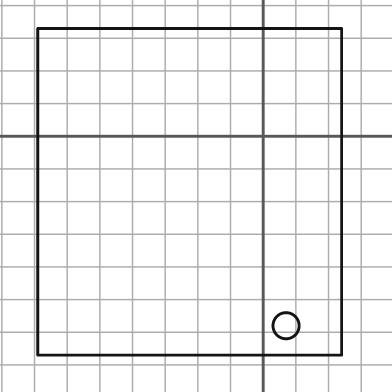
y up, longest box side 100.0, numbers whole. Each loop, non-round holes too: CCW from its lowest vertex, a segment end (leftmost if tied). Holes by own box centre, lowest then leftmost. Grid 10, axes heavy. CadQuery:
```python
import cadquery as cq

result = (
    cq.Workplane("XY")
    .moveTo(-69.0, -67.0)
    .lineTo(24.0, -67.0)
    .lineTo(24.0, 33.0)
    .lineTo(-69.0, 33.0)
    .close()
    .moveTo(7.0, -58.0)
    .circle(4.0)
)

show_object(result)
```